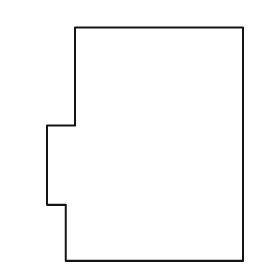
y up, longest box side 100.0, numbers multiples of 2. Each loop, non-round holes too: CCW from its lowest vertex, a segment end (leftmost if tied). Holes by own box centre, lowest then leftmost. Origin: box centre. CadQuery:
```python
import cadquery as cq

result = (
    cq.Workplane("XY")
    .moveTo(-34.0, -50.0)
    .lineTo(42.0, -50.0)
    .lineTo(42.0, 50.0)
    .lineTo(-30.0, 50.0)
    .lineTo(-30.0, 8.0)
    .lineTo(-42.0, 8.0)
    .lineTo(-42.0, -26.0)
    .lineTo(-34.0, -26.0)
    .close()
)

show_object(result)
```